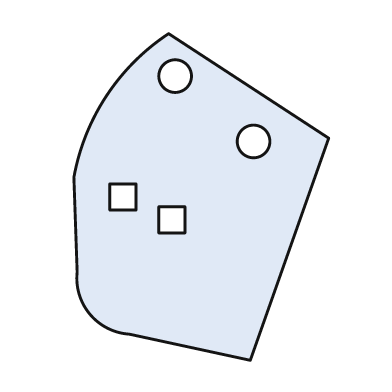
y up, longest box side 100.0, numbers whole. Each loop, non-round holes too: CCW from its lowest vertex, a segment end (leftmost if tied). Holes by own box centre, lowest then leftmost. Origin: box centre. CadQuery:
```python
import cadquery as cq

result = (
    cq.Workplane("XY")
    .moveTo(15.0, -50.0)
    .lineTo(39.0, 18.0)
    .lineTo(-10.0, 50.0)
    .threePointArc((-29.0, 31.0), (-39.0, 6.0))
    .lineTo(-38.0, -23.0)
    .threePointArc((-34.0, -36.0), (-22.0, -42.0))
    .close()
    .moveTo(-13.0, -11.0)
    .lineTo(-5.0, -11.0)
    .lineTo(-5.0, -3.0)
    .lineTo(-13.0, -3.0)
    .close()
    .moveTo(-28.0, -4.0)
    .lineTo(-20.0, -4.0)
    .lineTo(-20.0, 4.0)
    .lineTo(-28.0, 4.0)
    .close()
    .moveTo(16.0, 17.0)
    .circle(5.0)
    .moveTo(-8.0, 37.0)
    .circle(5.0)
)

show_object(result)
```